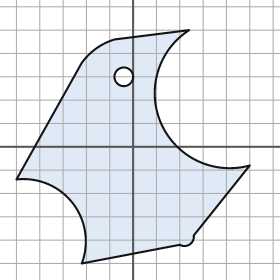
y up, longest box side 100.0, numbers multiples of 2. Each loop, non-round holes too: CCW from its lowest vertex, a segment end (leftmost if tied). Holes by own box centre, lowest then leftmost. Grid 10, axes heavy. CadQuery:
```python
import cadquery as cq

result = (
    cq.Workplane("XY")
    .moveTo(-22.0, -50.0)
    .lineTo(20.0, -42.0)
    .threePointArc((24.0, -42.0), (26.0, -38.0))
    .lineTo(50.0, -8.0)
    .threePointArc((12.0, 10.0), (24.0, 50.0))
    .lineTo(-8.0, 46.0)
    .threePointArc((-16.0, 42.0), (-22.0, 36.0))
    .lineTo(-50.0, -14.0)
    .threePointArc((-26.0, -24.0), (-22.0, -50.0))
    .close()
    .moveTo(-4.0, 30.0)
    .circle(4.0)
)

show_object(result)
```